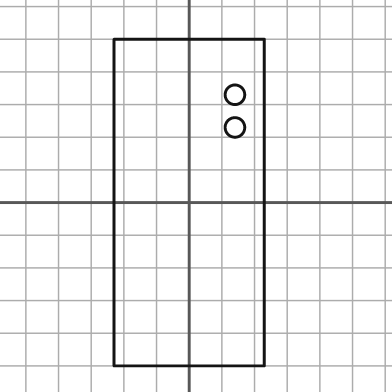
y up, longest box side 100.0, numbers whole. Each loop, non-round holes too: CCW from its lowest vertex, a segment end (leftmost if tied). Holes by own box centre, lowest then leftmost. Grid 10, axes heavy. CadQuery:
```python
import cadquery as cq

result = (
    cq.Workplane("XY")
    .moveTo(-23.0, -50.0)
    .lineTo(23.0, -50.0)
    .lineTo(23.0, 50.0)
    .lineTo(-23.0, 50.0)
    .close()
    .moveTo(14.0, 23.0)
    .circle(3.0)
    .moveTo(14.0, 33.0)
    .circle(3.0)
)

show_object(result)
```